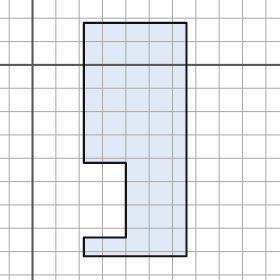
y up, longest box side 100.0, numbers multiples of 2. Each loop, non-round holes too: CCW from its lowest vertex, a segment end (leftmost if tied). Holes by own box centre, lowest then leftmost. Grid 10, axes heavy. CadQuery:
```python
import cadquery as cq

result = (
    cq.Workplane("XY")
    .moveTo(22.0, -82.0)
    .lineTo(66.0, -82.0)
    .lineTo(66.0, 18.0)
    .lineTo(22.0, 18.0)
    .lineTo(22.0, -42.0)
    .lineTo(40.0, -42.0)
    .lineTo(40.0, -74.0)
    .lineTo(22.0, -74.0)
    .close()
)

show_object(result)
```